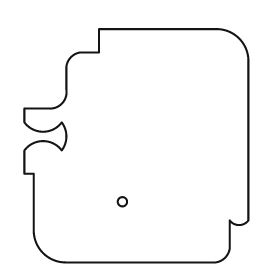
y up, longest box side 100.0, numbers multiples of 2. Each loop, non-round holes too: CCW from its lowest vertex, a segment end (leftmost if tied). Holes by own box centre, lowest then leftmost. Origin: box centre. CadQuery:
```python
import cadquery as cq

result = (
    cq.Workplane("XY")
    .moveTo(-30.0, -50.0)
    .lineTo(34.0, -50.0)
    .threePointArc((38.0, -48.0), (40.0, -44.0))
    .lineTo(40.0, -32.0)
    .threePointArc((44.0, -34.0), (48.0, -32.0))
    .lineTo(48.0, 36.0)
    .threePointArc((44.0, 46.0), (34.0, 50.0))
    .lineTo(-16.0, 50.0)
    .lineTo(-16.0, 40.0)
    .lineTo(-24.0, 40.0)
    .threePointArc((-28.0, 38.0), (-30.0, 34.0))
    .lineTo(-30.0, 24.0)
    .threePointArc((-32.0, 18.0), (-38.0, 16.0))
    .lineTo(-48.0, 16.0)
    .lineTo(-48.0, 10.0)
    .threePointArc((-40.0, 6.0), (-32.0, 10.0))
    .threePointArc((-30.0, 4.0), (-32.0, -2.0))
    .threePointArc((-40.0, 2.0), (-48.0, -2.0))
    .lineTo(-48.0, -12.0)
    .lineTo(-44.0, -12.0)
    .lineTo(-44.0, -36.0)
    .threePointArc((-40.0, -46.0), (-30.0, -50.0))
    .close()
    .moveTo(-6.0, -24.0)
    .circle(2.0)
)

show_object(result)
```